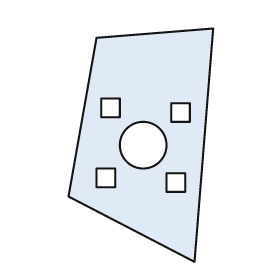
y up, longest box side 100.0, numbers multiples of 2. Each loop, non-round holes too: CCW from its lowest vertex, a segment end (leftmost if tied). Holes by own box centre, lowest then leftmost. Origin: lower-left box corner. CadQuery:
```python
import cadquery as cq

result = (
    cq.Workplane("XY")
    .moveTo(54.0, 0.0)
    .lineTo(62.0, 100.0)
    .lineTo(12.0, 96.0)
    .lineTo(0.0, 28.0)
    .close()
    .moveTo(42.0, 30.0)
    .lineTo(50.0, 30.0)
    .lineTo(50.0, 38.0)
    .lineTo(42.0, 38.0)
    .close()
    .moveTo(12.0, 32.0)
    .lineTo(20.0, 32.0)
    .lineTo(20.0, 40.0)
    .lineTo(12.0, 40.0)
    .close()
    .moveTo(32.0, 50.0)
    .circle(10.0)
    .moveTo(44.0, 60.0)
    .lineTo(52.0, 60.0)
    .lineTo(52.0, 68.0)
    .lineTo(44.0, 68.0)
    .close()
    .moveTo(14.0, 62.0)
    .lineTo(22.0, 62.0)
    .lineTo(22.0, 70.0)
    .lineTo(14.0, 70.0)
    .close()
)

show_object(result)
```